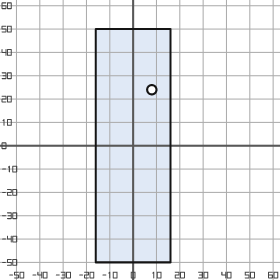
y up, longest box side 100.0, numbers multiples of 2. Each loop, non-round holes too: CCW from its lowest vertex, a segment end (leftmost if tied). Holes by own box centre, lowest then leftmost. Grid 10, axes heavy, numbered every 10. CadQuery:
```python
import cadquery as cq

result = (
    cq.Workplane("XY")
    .moveTo(-16.0, -50.0)
    .lineTo(16.0, -50.0)
    .lineTo(16.0, 50.0)
    .lineTo(-16.0, 50.0)
    .close()
    .moveTo(8.0, 24.0)
    .circle(2.0)
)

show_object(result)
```